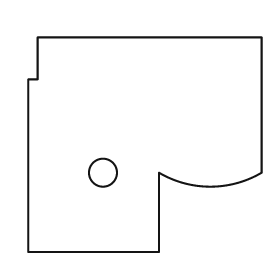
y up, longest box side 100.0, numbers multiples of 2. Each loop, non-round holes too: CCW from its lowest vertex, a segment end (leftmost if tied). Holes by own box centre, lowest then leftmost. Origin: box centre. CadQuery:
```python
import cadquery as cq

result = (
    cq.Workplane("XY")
    .moveTo(-50.0, -46.0)
    .lineTo(6.0, -46.0)
    .lineTo(6.0, -12.0)
    .threePointArc((28.0, -18.0), (50.0, -12.0))
    .lineTo(50.0, 46.0)
    .lineTo(-46.0, 46.0)
    .lineTo(-46.0, 28.0)
    .lineTo(-50.0, 28.0)
    .close()
    .moveTo(-18.0, -12.0)
    .circle(6.0)
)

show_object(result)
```